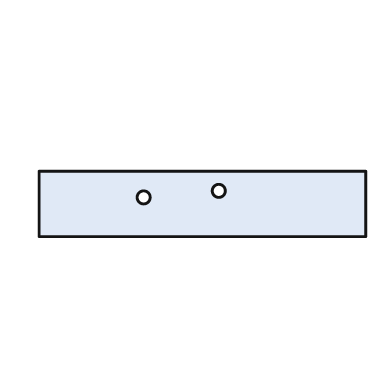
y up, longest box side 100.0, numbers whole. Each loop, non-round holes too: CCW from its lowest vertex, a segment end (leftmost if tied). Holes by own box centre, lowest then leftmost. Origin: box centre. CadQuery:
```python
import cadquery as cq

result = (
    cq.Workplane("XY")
    .moveTo(-50.0, -10.0)
    .lineTo(50.0, -10.0)
    .lineTo(50.0, 10.0)
    .lineTo(-50.0, 10.0)
    .close()
    .moveTo(-18.0, 2.0)
    .circle(2.0)
    .moveTo(5.0, 4.0)
    .circle(2.0)
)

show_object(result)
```